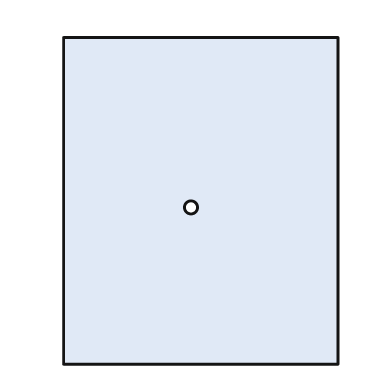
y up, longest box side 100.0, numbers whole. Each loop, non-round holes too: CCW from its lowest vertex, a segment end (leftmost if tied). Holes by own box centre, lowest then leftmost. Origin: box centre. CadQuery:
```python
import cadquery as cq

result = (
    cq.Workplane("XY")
    .moveTo(-42.0, -50.0)
    .lineTo(42.0, -50.0)
    .lineTo(42.0, 50.0)
    .lineTo(-42.0, 50.0)
    .close()
    .moveTo(-3.0, -2.0)
    .circle(2.0)
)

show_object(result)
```